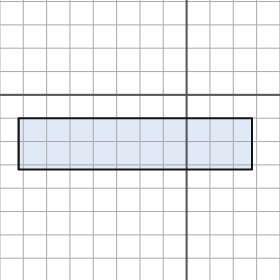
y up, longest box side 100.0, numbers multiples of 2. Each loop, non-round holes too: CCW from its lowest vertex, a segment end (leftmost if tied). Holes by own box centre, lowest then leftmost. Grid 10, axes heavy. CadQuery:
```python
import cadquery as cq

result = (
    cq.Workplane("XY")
    .moveTo(-72.0, -32.0)
    .lineTo(28.0, -32.0)
    .lineTo(28.0, -10.0)
    .lineTo(-72.0, -10.0)
    .close()
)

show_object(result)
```